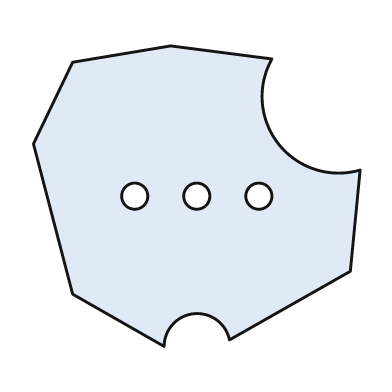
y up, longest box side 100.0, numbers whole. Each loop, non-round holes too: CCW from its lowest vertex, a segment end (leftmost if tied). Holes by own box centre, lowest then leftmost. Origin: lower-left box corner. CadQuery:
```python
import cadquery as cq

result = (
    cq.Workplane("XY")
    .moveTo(40.0, 0.0)
    .threePointArc((49.0, 10.0), (60.0, 2.0))
    .lineTo(97.0, 23.0)
    .lineTo(100.0, 54.0)
    .threePointArc((75.0, 62.0), (73.0, 88.0))
    .lineTo(42.0, 92.0)
    .lineTo(12.0, 87.0)
    .lineTo(0.0, 62.0)
    .lineTo(12.0, 16.0)
    .close()
    .moveTo(31.0, 46.0)
    .circle(4.0)
    .moveTo(50.0, 46.0)
    .circle(4.0)
    .moveTo(69.0, 46.0)
    .circle(4.0)
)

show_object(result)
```